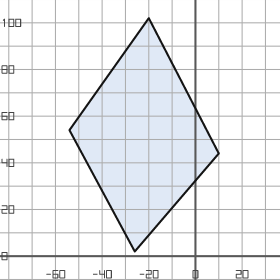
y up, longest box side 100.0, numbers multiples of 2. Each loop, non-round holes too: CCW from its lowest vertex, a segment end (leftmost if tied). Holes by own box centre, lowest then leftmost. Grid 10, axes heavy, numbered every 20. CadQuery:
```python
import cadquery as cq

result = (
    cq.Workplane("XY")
    .moveTo(-26.0, 2.0)
    .lineTo(10.0, 44.0)
    .lineTo(-20.0, 102.0)
    .lineTo(-54.0, 54.0)
    .close()
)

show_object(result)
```